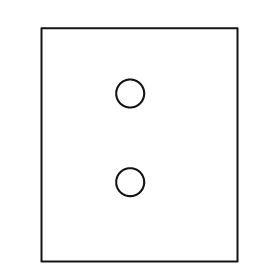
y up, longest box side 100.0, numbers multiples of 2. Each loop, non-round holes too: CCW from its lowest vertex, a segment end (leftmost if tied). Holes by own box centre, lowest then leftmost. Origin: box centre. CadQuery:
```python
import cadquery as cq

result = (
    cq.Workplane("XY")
    .moveTo(-42.0, -50.0)
    .lineTo(42.0, -50.0)
    .lineTo(42.0, 50.0)
    .lineTo(-42.0, 50.0)
    .close()
    .moveTo(-4.0, -16.0)
    .circle(6.0)
    .moveTo(-4.0, 22.0)
    .circle(6.0)
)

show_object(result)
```